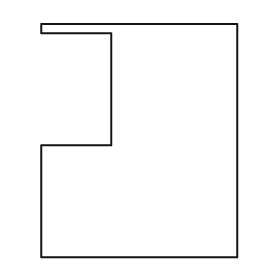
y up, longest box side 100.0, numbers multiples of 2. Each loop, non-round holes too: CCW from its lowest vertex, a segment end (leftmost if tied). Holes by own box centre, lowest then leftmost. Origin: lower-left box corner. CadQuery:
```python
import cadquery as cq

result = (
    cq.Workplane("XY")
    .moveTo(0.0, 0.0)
    .lineTo(84.0, 0.0)
    .lineTo(84.0, 100.0)
    .lineTo(0.0, 100.0)
    .lineTo(0.0, 96.0)
    .lineTo(30.0, 96.0)
    .lineTo(30.0, 48.0)
    .lineTo(0.0, 48.0)
    .close()
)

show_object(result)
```